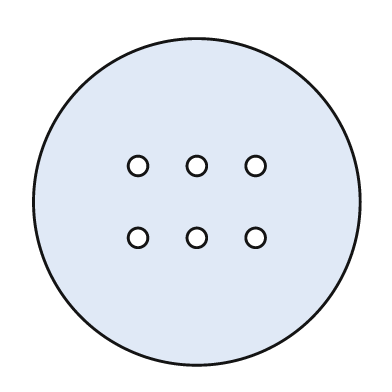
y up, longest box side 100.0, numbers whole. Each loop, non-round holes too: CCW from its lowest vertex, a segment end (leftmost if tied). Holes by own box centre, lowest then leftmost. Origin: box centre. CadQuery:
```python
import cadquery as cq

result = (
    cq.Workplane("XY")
    .moveTo(0.0, 0.0)
    .circle(50.0)
    .moveTo(-18.0, -11.0)
    .circle(3.0)
    .moveTo(0.0, -11.0)
    .circle(3.0)
    .moveTo(18.0, -11.0)
    .circle(3.0)
    .moveTo(-18.0, 11.0)
    .circle(3.0)
    .moveTo(0.0, 11.0)
    .circle(3.0)
    .moveTo(18.0, 11.0)
    .circle(3.0)
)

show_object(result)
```